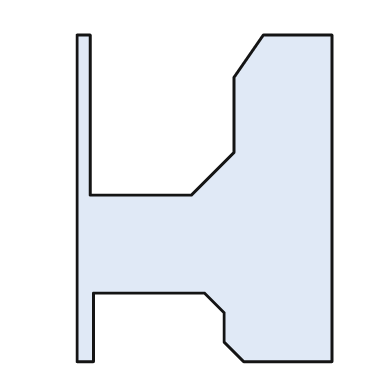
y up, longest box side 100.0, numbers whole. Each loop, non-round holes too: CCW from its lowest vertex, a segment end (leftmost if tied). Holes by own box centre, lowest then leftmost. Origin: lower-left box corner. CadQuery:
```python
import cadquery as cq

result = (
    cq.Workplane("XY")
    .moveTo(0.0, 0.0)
    .lineTo(5.0, 0.0)
    .lineTo(5.0, 21.0)
    .lineTo(39.0, 21.0)
    .lineTo(45.0, 15.0)
    .lineTo(45.0, 6.0)
    .lineTo(51.0, 0.0)
    .lineTo(78.0, 0.0)
    .lineTo(78.0, 100.0)
    .lineTo(57.0, 100.0)
    .lineTo(48.0, 87.0)
    .lineTo(48.0, 64.0)
    .lineTo(35.0, 51.0)
    .lineTo(4.0, 51.0)
    .lineTo(4.0, 100.0)
    .lineTo(0.0, 100.0)
    .close()
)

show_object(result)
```